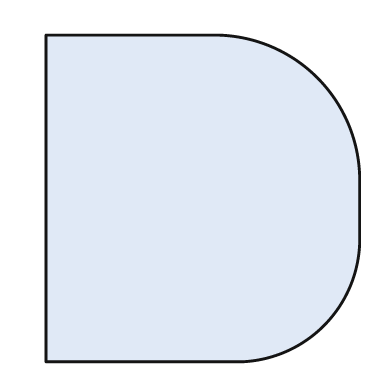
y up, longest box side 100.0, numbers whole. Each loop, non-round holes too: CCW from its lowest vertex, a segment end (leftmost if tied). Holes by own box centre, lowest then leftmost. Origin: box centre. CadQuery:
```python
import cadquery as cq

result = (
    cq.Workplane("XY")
    .moveTo(-48.0, -50.0)
    .lineTo(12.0, -50.0)
    .threePointArc((37.0, -39.0), (48.0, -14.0))
    .lineTo(48.0, 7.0)
    .threePointArc((35.0, 37.0), (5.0, 50.0))
    .lineTo(-48.0, 50.0)
    .close()
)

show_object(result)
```